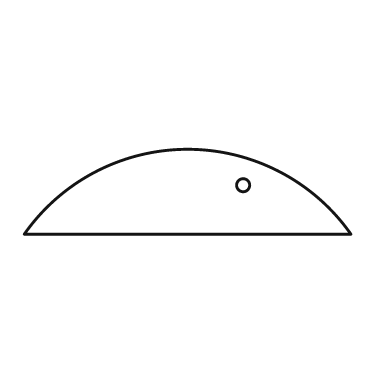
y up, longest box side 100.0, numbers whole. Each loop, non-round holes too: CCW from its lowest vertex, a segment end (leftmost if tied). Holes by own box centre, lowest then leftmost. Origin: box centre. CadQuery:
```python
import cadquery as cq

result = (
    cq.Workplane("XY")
    .moveTo(-50.0, -13.0)
    .lineTo(50.0, -13.0)
    .threePointArc((0.0, 13.0), (-50.0, -13.0))
    .close()
    .moveTo(17.0, 2.0)
    .circle(2.0)
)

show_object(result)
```